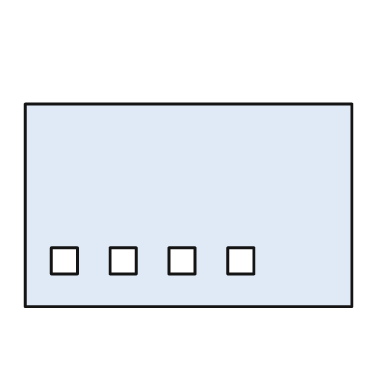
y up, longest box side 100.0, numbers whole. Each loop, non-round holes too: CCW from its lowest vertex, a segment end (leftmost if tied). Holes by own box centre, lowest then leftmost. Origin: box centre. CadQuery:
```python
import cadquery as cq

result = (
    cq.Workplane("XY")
    .moveTo(-50.0, -31.0)
    .lineTo(50.0, -31.0)
    .lineTo(50.0, 31.0)
    .lineTo(-50.0, 31.0)
    .close()
    .moveTo(-42.0, -21.0)
    .lineTo(-34.0, -21.0)
    .lineTo(-34.0, -13.0)
    .lineTo(-42.0, -13.0)
    .close()
    .moveTo(-24.0, -21.0)
    .lineTo(-16.0, -21.0)
    .lineTo(-16.0, -13.0)
    .lineTo(-24.0, -13.0)
    .close()
    .moveTo(-6.0, -21.0)
    .lineTo(2.0, -21.0)
    .lineTo(2.0, -13.0)
    .lineTo(-6.0, -13.0)
    .close()
    .moveTo(12.0, -21.0)
    .lineTo(20.0, -21.0)
    .lineTo(20.0, -13.0)
    .lineTo(12.0, -13.0)
    .close()
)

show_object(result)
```